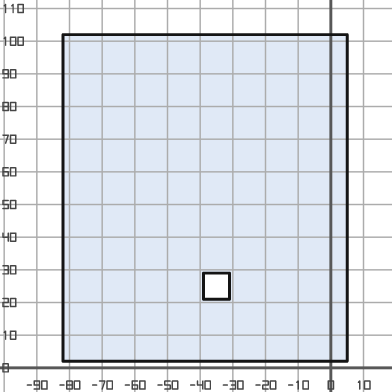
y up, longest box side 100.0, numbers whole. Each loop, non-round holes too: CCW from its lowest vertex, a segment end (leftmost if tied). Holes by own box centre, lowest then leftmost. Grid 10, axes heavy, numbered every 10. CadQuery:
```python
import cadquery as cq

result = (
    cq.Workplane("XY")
    .moveTo(-82.0, 2.0)
    .lineTo(5.0, 2.0)
    .lineTo(5.0, 102.0)
    .lineTo(-82.0, 102.0)
    .close()
    .moveTo(-39.0, 21.0)
    .lineTo(-31.0, 21.0)
    .lineTo(-31.0, 29.0)
    .lineTo(-39.0, 29.0)
    .close()
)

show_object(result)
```